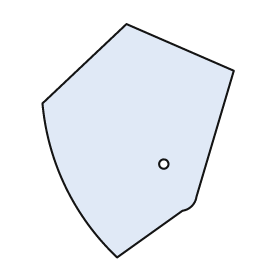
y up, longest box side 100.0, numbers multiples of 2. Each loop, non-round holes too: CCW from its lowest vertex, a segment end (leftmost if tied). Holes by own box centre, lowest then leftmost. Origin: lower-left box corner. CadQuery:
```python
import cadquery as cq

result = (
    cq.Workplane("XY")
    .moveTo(32.0, 0.0)
    .lineTo(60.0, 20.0)
    .threePointArc((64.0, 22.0), (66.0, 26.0))
    .lineTo(82.0, 80.0)
    .lineTo(36.0, 100.0)
    .lineTo(0.0, 66.0)
    .threePointArc((10.0, 30.0), (32.0, 0.0))
    .close()
    .moveTo(52.0, 40.0)
    .circle(2.0)
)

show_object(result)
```